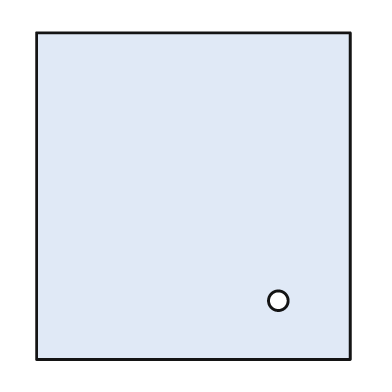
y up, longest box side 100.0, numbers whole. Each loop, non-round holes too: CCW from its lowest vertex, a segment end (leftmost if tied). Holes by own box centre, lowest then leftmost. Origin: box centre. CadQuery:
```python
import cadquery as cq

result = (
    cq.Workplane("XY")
    .moveTo(-48.0, -50.0)
    .lineTo(48.0, -50.0)
    .lineTo(48.0, 50.0)
    .lineTo(-48.0, 50.0)
    .close()
    .moveTo(26.0, -32.0)
    .circle(3.0)
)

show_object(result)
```